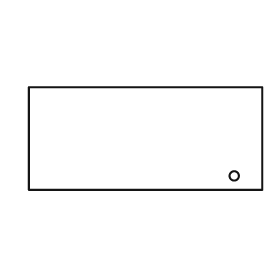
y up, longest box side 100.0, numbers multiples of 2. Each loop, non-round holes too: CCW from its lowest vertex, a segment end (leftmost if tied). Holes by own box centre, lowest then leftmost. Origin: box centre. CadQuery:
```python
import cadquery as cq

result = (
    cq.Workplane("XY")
    .moveTo(-50.0, -22.0)
    .lineTo(50.0, -22.0)
    .lineTo(50.0, 22.0)
    .lineTo(-50.0, 22.0)
    .close()
    .moveTo(38.0, -16.0)
    .circle(2.0)
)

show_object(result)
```